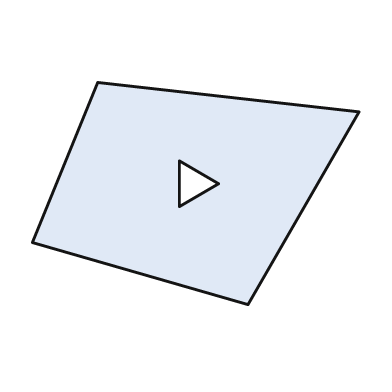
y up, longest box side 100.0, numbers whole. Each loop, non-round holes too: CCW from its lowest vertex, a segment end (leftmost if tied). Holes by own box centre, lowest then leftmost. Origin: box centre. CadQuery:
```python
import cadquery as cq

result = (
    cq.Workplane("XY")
    .moveTo(16.0, -34.0)
    .lineTo(50.0, 25.0)
    .lineTo(-30.0, 34.0)
    .lineTo(-50.0, -15.0)
    .close()
    .moveTo(-5.0, -4.0)
    .lineTo(7.0, 3.0)
    .lineTo(-5.0, 10.0)
    .close()
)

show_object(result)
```